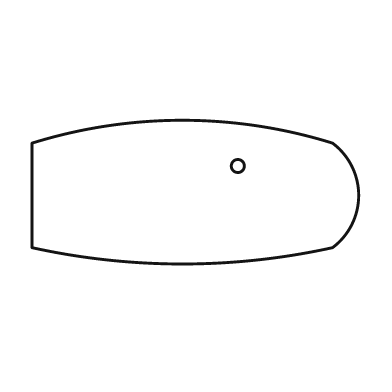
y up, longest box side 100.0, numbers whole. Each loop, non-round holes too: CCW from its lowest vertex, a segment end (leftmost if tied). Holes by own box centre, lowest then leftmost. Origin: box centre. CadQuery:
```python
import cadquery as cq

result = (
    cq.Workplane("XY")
    .moveTo(-50.0, -17.0)
    .threePointArc((-4.0, -22.0), (42.0, -17.0))
    .threePointArc((50.0, -1.0), (42.0, 15.0))
    .threePointArc((-4.0, 22.0), (-50.0, 15.0))
    .close()
    .moveTo(13.0, 8.0)
    .circle(2.0)
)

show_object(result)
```